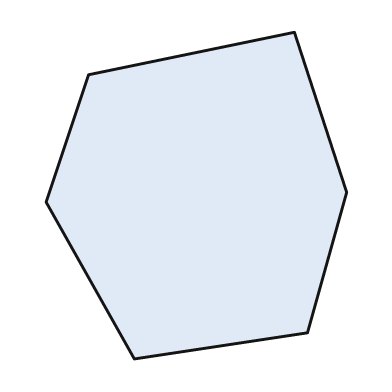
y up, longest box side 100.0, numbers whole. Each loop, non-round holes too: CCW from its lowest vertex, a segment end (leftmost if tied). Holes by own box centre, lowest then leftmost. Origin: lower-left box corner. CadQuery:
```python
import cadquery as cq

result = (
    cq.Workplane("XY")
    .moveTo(27.0, 0.0)
    .lineTo(80.0, 8.0)
    .lineTo(92.0, 51.0)
    .lineTo(76.0, 100.0)
    .lineTo(13.0, 87.0)
    .lineTo(0.0, 48.0)
    .close()
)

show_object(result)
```